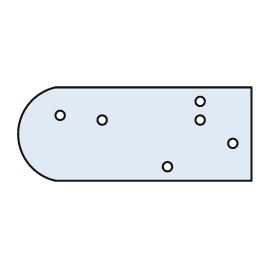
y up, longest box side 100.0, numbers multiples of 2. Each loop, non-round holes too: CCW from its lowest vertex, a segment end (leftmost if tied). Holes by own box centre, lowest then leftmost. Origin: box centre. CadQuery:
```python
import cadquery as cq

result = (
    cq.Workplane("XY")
    .moveTo(-34.0, -20.0)
    .lineTo(50.0, -20.0)
    .lineTo(50.0, 20.0)
    .lineTo(-34.0, 20.0)
    .threePointArc((-50.0, 0.0), (-34.0, -20.0))
    .close()
    .moveTo(14.0, -14.0)
    .circle(2.0)
    .moveTo(42.0, -4.0)
    .circle(2.0)
    .moveTo(-14.0, 6.0)
    .circle(2.0)
    .moveTo(28.0, 6.0)
    .circle(2.0)
    .moveTo(-32.0, 8.0)
    .circle(2.0)
    .moveTo(28.0, 14.0)
    .circle(2.0)
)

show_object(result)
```